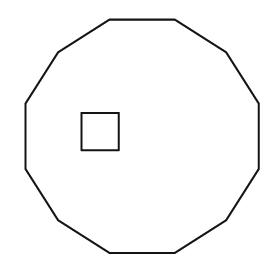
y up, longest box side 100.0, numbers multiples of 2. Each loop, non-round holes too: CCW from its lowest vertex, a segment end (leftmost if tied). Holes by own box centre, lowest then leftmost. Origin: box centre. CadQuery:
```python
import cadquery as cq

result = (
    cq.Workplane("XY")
    .moveTo(-14.0, -50.0)
    .lineTo(14.0, -50.0)
    .lineTo(36.0, -36.0)
    .lineTo(50.0, -14.0)
    .lineTo(50.0, 14.0)
    .lineTo(36.0, 36.0)
    .lineTo(14.0, 50.0)
    .lineTo(-14.0, 50.0)
    .lineTo(-36.0, 36.0)
    .lineTo(-50.0, 14.0)
    .lineTo(-50.0, -14.0)
    .lineTo(-36.0, -36.0)
    .close()
    .moveTo(-26.0, -6.0)
    .lineTo(-10.0, -6.0)
    .lineTo(-10.0, 10.0)
    .lineTo(-26.0, 10.0)
    .close()
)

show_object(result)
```